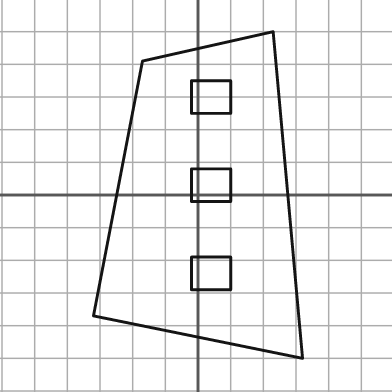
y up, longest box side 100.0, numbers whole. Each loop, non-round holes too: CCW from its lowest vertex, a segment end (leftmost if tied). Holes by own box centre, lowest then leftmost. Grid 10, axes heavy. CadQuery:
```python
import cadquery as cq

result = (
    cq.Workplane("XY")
    .moveTo(32.0, -50.0)
    .lineTo(23.0, 50.0)
    .lineTo(-17.0, 41.0)
    .lineTo(-32.0, -37.0)
    .close()
    .moveTo(-2.0, -29.0)
    .lineTo(10.0, -29.0)
    .lineTo(10.0, -19.0)
    .lineTo(-2.0, -19.0)
    .close()
    .moveTo(-2.0, -2.0)
    .lineTo(10.0, -2.0)
    .lineTo(10.0, 8.0)
    .lineTo(-2.0, 8.0)
    .close()
    .moveTo(-2.0, 25.0)
    .lineTo(10.0, 25.0)
    .lineTo(10.0, 35.0)
    .lineTo(-2.0, 35.0)
    .close()
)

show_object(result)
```